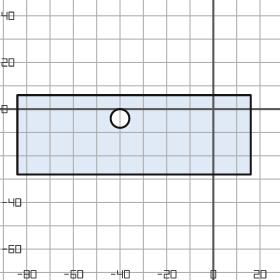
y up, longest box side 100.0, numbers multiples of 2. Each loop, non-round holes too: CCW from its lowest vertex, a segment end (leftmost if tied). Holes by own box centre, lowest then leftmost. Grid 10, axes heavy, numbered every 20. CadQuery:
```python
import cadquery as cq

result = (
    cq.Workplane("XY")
    .moveTo(-84.0, -28.0)
    .lineTo(16.0, -28.0)
    .lineTo(16.0, 6.0)
    .lineTo(-84.0, 6.0)
    .close()
    .moveTo(-40.0, -4.0)
    .circle(4.0)
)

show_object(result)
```